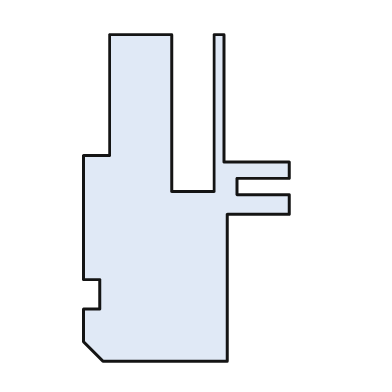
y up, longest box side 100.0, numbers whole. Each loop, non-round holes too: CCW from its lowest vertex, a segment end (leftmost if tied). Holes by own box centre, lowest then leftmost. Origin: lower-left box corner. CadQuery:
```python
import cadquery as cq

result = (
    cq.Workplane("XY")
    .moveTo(6.0, 0.0)
    .lineTo(44.0, 0.0)
    .lineTo(44.0, 45.0)
    .lineTo(63.0, 45.0)
    .lineTo(63.0, 51.0)
    .lineTo(47.0, 51.0)
    .lineTo(47.0, 56.0)
    .lineTo(63.0, 56.0)
    .lineTo(63.0, 61.0)
    .lineTo(43.0, 61.0)
    .lineTo(43.0, 100.0)
    .lineTo(40.0, 100.0)
    .lineTo(40.0, 52.0)
    .lineTo(27.0, 52.0)
    .lineTo(27.0, 100.0)
    .lineTo(8.0, 100.0)
    .lineTo(8.0, 63.0)
    .lineTo(0.0, 63.0)
    .lineTo(0.0, 25.0)
    .lineTo(5.0, 25.0)
    .lineTo(5.0, 16.0)
    .lineTo(0.0, 16.0)
    .lineTo(0.0, 6.0)
    .close()
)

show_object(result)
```